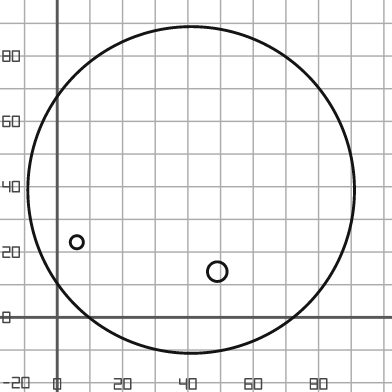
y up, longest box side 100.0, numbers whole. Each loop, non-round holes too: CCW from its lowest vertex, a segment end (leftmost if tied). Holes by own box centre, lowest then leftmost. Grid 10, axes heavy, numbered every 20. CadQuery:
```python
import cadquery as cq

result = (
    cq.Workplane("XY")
    .moveTo(41.0, 39.0)
    .circle(50.0)
    .moveTo(49.0, 14.0)
    .circle(3.0)
    .moveTo(6.0, 23.0)
    .circle(2.0)
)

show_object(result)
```